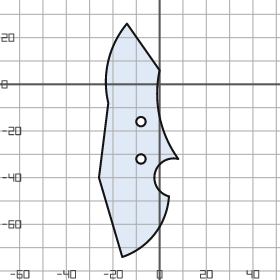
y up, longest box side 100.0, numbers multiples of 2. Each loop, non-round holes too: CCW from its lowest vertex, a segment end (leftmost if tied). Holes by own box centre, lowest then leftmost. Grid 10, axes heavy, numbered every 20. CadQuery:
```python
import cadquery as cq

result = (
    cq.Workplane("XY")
    .moveTo(-16.0, -74.0)
    .threePointArc((-2.0, -64.0), (4.0, -48.0))
    .threePointArc((-2.0, -38.0), (8.0, -32.0))
    .threePointArc((0.0, -14.0), (0.0, 6.0))
    .lineTo(-14.0, 26.0)
    .threePointArc((-22.0, 10.0), (-22.0, -8.0))
    .lineTo(-26.0, -40.0)
    .close()
    .moveTo(-8.0, -32.0)
    .circle(2.0)
    .moveTo(-8.0, -16.0)
    .circle(2.0)
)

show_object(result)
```